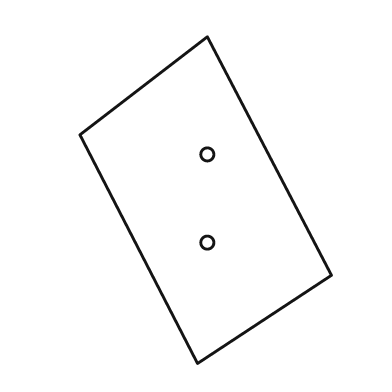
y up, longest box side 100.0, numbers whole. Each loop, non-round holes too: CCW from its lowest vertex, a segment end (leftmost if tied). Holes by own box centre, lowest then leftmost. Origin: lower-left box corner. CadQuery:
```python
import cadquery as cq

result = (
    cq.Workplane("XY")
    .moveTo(36.0, 0.0)
    .lineTo(77.0, 27.0)
    .lineTo(39.0, 100.0)
    .lineTo(0.0, 70.0)
    .close()
    .moveTo(39.0, 37.0)
    .circle(2.0)
    .moveTo(39.0, 64.0)
    .circle(2.0)
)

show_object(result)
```